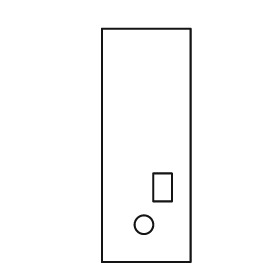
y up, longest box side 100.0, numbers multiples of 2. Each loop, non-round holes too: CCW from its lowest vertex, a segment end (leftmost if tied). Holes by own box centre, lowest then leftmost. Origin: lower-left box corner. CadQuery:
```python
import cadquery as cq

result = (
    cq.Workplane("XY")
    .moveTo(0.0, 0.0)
    .lineTo(38.0, 0.0)
    .lineTo(38.0, 100.0)
    .lineTo(0.0, 100.0)
    .close()
    .moveTo(18.0, 16.0)
    .circle(4.0)
    .moveTo(22.0, 26.0)
    .lineTo(30.0, 26.0)
    .lineTo(30.0, 38.0)
    .lineTo(22.0, 38.0)
    .close()
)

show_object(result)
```